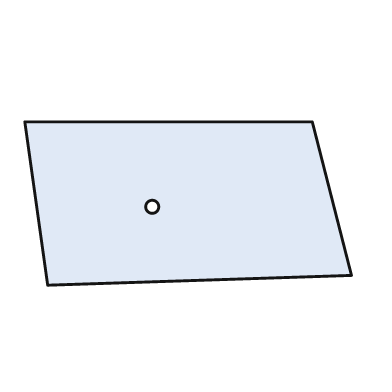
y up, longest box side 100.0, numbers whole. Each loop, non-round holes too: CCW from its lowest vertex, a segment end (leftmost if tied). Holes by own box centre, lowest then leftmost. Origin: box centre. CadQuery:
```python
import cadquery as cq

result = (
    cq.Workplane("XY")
    .moveTo(-43.0, -25.0)
    .lineTo(50.0, -22.0)
    .lineTo(38.0, 25.0)
    .lineTo(-50.0, 25.0)
    .close()
    .moveTo(-11.0, -1.0)
    .circle(2.0)
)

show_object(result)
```